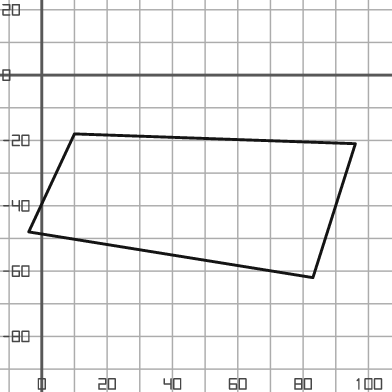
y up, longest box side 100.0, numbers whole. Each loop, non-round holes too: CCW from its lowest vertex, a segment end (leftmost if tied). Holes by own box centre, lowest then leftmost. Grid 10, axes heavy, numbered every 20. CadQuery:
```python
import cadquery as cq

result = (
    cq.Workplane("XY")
    .moveTo(83.0, -62.0)
    .lineTo(96.0, -21.0)
    .lineTo(10.0, -18.0)
    .lineTo(-4.0, -48.0)
    .close()
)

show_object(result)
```